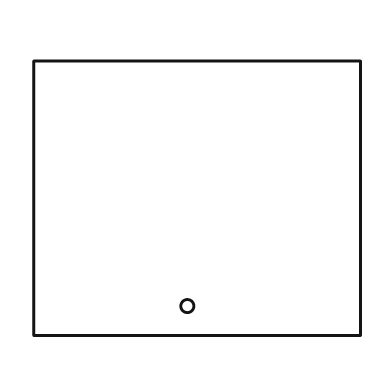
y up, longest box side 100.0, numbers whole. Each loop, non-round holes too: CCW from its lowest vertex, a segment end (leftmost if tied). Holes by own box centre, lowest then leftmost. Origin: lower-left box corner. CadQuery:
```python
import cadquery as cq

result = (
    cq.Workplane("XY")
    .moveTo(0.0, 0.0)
    .lineTo(100.0, 0.0)
    .lineTo(100.0, 84.0)
    .lineTo(0.0, 84.0)
    .close()
    .moveTo(47.0, 9.0)
    .circle(2.0)
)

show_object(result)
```